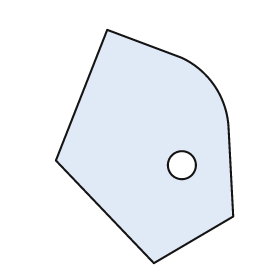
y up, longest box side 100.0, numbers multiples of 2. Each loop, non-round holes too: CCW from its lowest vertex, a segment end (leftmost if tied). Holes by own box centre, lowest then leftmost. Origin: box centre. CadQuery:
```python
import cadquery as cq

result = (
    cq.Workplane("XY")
    .moveTo(4.0, -50.0)
    .lineTo(38.0, -30.0)
    .lineTo(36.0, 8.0)
    .threePointArc((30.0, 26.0), (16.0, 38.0))
    .lineTo(-16.0, 50.0)
    .lineTo(-38.0, -6.0)
    .close()
    .moveTo(16.0, -8.0)
    .circle(6.0)
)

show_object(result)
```